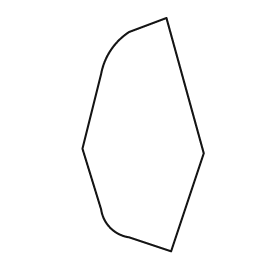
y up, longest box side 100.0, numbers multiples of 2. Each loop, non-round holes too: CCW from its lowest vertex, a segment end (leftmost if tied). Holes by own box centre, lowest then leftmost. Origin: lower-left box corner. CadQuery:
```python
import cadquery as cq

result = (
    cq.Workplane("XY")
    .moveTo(38.0, 0.0)
    .lineTo(52.0, 42.0)
    .lineTo(36.0, 100.0)
    .lineTo(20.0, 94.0)
    .threePointArc((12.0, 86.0), (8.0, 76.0))
    .lineTo(0.0, 44.0)
    .lineTo(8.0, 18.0)
    .threePointArc((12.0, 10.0), (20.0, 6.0))
    .close()
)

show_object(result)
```